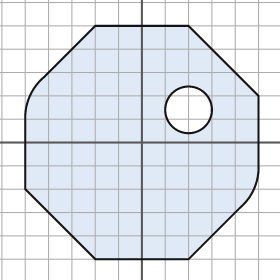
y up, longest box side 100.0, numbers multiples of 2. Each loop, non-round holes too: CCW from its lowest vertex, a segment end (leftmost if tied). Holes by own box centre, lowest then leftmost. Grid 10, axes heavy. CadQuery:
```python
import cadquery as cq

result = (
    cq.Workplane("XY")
    .moveTo(-20.0, -50.0)
    .lineTo(20.0, -50.0)
    .lineTo(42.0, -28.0)
    .threePointArc((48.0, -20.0), (50.0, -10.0))
    .lineTo(50.0, 20.0)
    .lineTo(20.0, 50.0)
    .lineTo(-20.0, 50.0)
    .lineTo(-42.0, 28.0)
    .threePointArc((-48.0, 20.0), (-50.0, 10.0))
    .lineTo(-50.0, -20.0)
    .close()
    .moveTo(20.0, 14.0)
    .circle(10.0)
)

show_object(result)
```